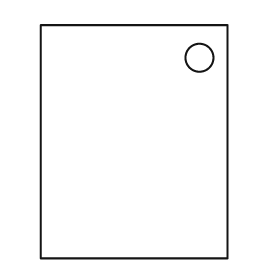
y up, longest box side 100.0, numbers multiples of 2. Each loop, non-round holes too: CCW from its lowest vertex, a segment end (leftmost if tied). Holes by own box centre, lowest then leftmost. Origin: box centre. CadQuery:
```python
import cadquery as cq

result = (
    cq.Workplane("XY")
    .moveTo(-40.0, -50.0)
    .lineTo(40.0, -50.0)
    .lineTo(40.0, 50.0)
    .lineTo(-40.0, 50.0)
    .close()
    .moveTo(28.0, 36.0)
    .circle(6.0)
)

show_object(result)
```